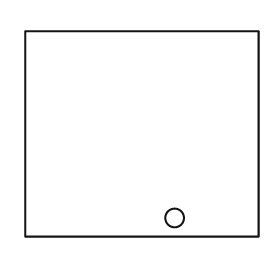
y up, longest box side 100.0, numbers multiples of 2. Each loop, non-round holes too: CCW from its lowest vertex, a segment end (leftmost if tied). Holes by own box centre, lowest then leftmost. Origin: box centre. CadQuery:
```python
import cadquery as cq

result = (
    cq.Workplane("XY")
    .moveTo(-50.0, -44.0)
    .lineTo(50.0, -44.0)
    .lineTo(50.0, 44.0)
    .lineTo(-50.0, 44.0)
    .close()
    .moveTo(14.0, -36.0)
    .circle(4.0)
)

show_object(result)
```